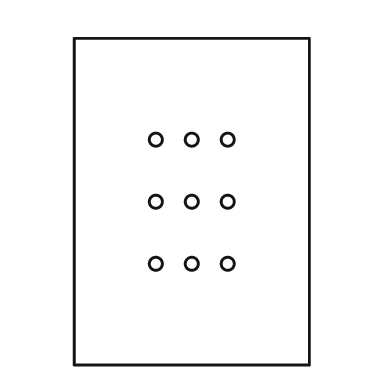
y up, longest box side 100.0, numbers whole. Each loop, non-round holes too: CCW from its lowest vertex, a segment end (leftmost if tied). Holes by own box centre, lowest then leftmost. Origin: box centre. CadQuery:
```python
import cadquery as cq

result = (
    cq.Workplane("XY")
    .moveTo(-36.0, -50.0)
    .lineTo(36.0, -50.0)
    .lineTo(36.0, 50.0)
    .lineTo(-36.0, 50.0)
    .close()
    .moveTo(-11.0, -19.0)
    .circle(2.0)
    .moveTo(0.0, -19.0)
    .circle(2.0)
    .moveTo(11.0, -19.0)
    .circle(2.0)
    .moveTo(-11.0, 0.0)
    .circle(2.0)
    .moveTo(0.0, 0.0)
    .circle(2.0)
    .moveTo(11.0, 0.0)
    .circle(2.0)
    .moveTo(-11.0, 19.0)
    .circle(2.0)
    .moveTo(0.0, 19.0)
    .circle(2.0)
    .moveTo(11.0, 19.0)
    .circle(2.0)
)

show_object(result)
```